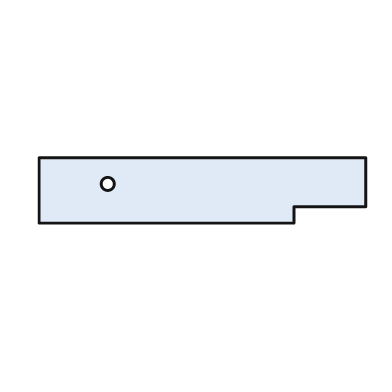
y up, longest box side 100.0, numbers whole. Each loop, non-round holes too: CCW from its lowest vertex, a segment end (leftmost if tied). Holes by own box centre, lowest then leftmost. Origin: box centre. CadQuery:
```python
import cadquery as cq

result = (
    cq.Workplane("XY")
    .moveTo(-50.0, -10.0)
    .lineTo(28.0, -10.0)
    .lineTo(28.0, -5.0)
    .lineTo(50.0, -5.0)
    .lineTo(50.0, 10.0)
    .lineTo(-50.0, 10.0)
    .close()
    .moveTo(-29.0, 2.0)
    .circle(2.0)
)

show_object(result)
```